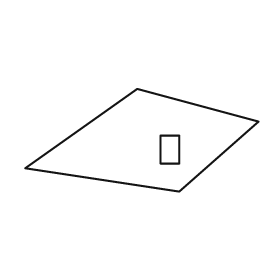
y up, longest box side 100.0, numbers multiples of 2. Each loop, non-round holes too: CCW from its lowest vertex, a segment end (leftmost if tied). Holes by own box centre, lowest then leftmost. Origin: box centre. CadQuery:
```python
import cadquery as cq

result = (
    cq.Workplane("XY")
    .moveTo(16.0, -22.0)
    .lineTo(50.0, 8.0)
    .lineTo(-2.0, 22.0)
    .lineTo(-50.0, -12.0)
    .close()
    .moveTo(8.0, -10.0)
    .lineTo(16.0, -10.0)
    .lineTo(16.0, 2.0)
    .lineTo(8.0, 2.0)
    .close()
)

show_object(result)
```